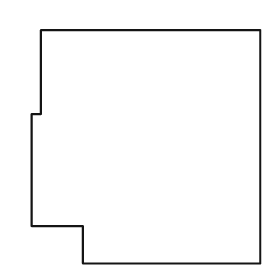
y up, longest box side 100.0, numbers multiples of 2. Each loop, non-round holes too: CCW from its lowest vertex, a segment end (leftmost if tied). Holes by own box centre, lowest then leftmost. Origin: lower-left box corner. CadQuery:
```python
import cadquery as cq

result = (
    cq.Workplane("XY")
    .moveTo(22.0, 0.0)
    .lineTo(98.0, 0.0)
    .lineTo(98.0, 100.0)
    .lineTo(4.0, 100.0)
    .lineTo(4.0, 64.0)
    .lineTo(0.0, 64.0)
    .lineTo(0.0, 16.0)
    .lineTo(22.0, 16.0)
    .close()
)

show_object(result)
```